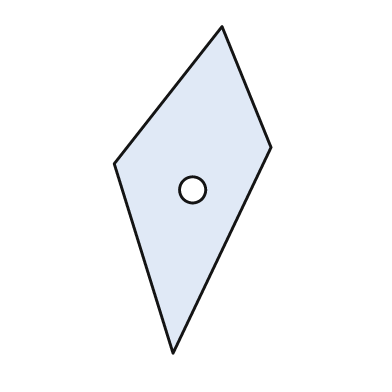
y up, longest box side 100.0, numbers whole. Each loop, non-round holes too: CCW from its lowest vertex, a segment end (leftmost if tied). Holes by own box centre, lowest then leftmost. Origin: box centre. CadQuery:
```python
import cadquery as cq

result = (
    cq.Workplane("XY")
    .moveTo(-6.0, -50.0)
    .lineTo(24.0, 13.0)
    .lineTo(9.0, 50.0)
    .lineTo(-24.0, 8.0)
    .close()
    .moveTo(0.0, 0.0)
    .circle(4.0)
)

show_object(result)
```